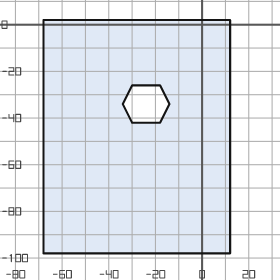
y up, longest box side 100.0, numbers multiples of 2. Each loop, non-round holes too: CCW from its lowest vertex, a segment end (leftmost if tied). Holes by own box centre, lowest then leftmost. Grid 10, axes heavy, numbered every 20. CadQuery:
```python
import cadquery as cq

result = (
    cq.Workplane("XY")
    .moveTo(-68.0, -98.0)
    .lineTo(12.0, -98.0)
    .lineTo(12.0, 2.0)
    .lineTo(-68.0, 2.0)
    .close()
    .moveTo(-30.0, -42.0)
    .lineTo(-18.0, -42.0)
    .lineTo(-14.0, -34.0)
    .lineTo(-18.0, -26.0)
    .lineTo(-30.0, -26.0)
    .lineTo(-34.0, -34.0)
    .close()
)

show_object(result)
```